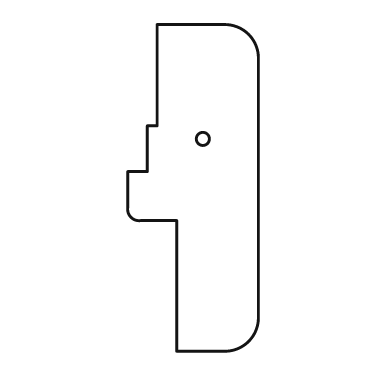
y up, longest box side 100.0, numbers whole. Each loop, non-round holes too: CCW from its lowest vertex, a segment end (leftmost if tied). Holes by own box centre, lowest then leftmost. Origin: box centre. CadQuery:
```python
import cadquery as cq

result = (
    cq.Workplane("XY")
    .moveTo(-5.0, -50.0)
    .lineTo(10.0, -50.0)
    .threePointArc((17.0, -47.0), (20.0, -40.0))
    .lineTo(20.0, 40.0)
    .threePointArc((17.0, 47.0), (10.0, 50.0))
    .lineTo(-11.0, 50.0)
    .lineTo(-11.0, 19.0)
    .lineTo(-14.0, 19.0)
    .lineTo(-14.0, 5.0)
    .lineTo(-20.0, 5.0)
    .lineTo(-20.0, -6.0)
    .threePointArc((-19.0, -9.0), (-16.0, -10.0))
    .lineTo(-5.0, -10.0)
    .close()
    .moveTo(3.0, 15.0)
    .circle(2.0)
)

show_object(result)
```